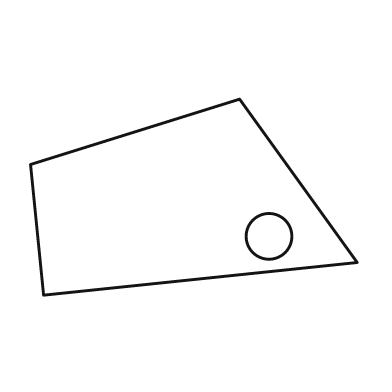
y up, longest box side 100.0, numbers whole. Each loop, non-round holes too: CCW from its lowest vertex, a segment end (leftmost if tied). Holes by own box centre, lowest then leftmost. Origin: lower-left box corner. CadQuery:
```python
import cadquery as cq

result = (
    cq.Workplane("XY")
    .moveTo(4.0, 0.0)
    .lineTo(100.0, 10.0)
    .lineTo(64.0, 60.0)
    .lineTo(0.0, 40.0)
    .close()
    .moveTo(73.0, 18.0)
    .circle(7.0)
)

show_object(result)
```